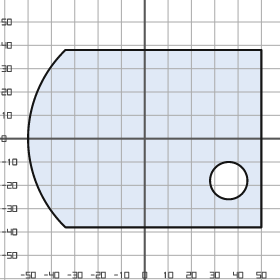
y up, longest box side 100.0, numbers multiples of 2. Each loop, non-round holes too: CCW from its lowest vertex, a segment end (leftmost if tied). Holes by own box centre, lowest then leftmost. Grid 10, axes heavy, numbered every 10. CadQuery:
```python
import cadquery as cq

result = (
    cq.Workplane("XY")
    .moveTo(-34.0, -38.0)
    .lineTo(50.0, -38.0)
    .lineTo(50.0, 38.0)
    .lineTo(-34.0, 38.0)
    .threePointArc((-50.0, 0.0), (-34.0, -38.0))
    .close()
    .moveTo(36.0, -18.0)
    .circle(8.0)
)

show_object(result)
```